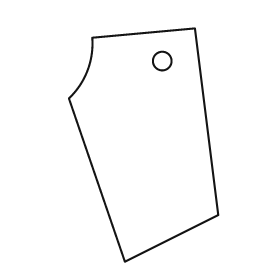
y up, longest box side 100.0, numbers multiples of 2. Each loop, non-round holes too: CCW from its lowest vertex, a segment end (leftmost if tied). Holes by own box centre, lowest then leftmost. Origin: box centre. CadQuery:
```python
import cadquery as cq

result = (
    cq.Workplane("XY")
    .moveTo(-8.0, -50.0)
    .lineTo(32.0, -30.0)
    .lineTo(22.0, 50.0)
    .lineTo(-22.0, 46.0)
    .threePointArc((-24.0, 32.0), (-32.0, 20.0))
    .close()
    .moveTo(8.0, 36.0)
    .circle(4.0)
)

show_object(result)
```